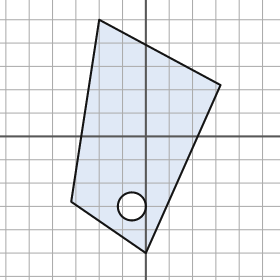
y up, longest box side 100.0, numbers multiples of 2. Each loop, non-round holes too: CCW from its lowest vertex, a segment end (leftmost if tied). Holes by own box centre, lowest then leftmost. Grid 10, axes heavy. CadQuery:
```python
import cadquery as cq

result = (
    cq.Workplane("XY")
    .moveTo(0.0, -50.0)
    .lineTo(32.0, 22.0)
    .lineTo(-20.0, 50.0)
    .lineTo(-32.0, -28.0)
    .close()
    .moveTo(-6.0, -30.0)
    .circle(6.0)
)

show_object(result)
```